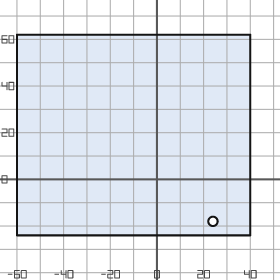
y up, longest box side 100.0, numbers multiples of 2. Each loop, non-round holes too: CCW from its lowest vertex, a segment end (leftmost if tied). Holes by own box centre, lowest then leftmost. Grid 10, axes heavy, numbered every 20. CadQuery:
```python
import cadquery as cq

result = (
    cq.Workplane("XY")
    .moveTo(-60.0, -24.0)
    .lineTo(40.0, -24.0)
    .lineTo(40.0, 62.0)
    .lineTo(-60.0, 62.0)
    .close()
    .moveTo(24.0, -18.0)
    .circle(2.0)
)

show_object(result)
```